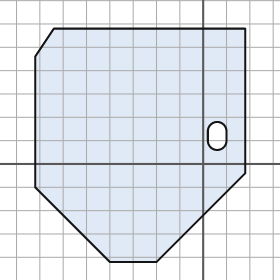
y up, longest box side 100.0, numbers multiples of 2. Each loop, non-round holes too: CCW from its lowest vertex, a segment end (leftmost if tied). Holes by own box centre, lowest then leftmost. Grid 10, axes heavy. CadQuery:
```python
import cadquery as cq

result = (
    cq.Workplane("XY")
    .moveTo(-40.0, -42.0)
    .lineTo(-20.0, -42.0)
    .lineTo(18.0, -4.0)
    .lineTo(18.0, 58.0)
    .lineTo(-64.0, 58.0)
    .lineTo(-72.0, 46.0)
    .lineTo(-72.0, -10.0)
    .close()
    .moveTo(2.0, 10.0)
    .threePointArc((6.0, 6.0), (10.0, 10.0))
    .lineTo(10.0, 14.0)
    .threePointArc((6.0, 18.0), (2.0, 14.0))
    .close()
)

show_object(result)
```